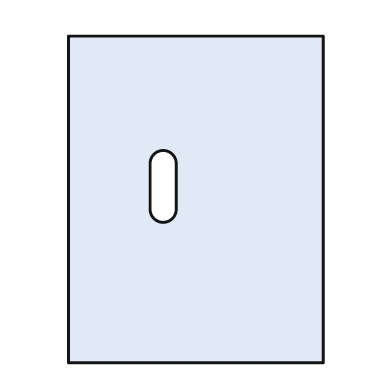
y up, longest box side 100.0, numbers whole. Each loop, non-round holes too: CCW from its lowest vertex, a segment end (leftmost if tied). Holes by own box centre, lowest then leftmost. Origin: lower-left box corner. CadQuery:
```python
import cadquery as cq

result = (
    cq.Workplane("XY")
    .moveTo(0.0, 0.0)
    .lineTo(78.0, 0.0)
    .lineTo(78.0, 100.0)
    .lineTo(0.0, 100.0)
    .close()
    .moveTo(25.0, 47.0)
    .threePointArc((29.0, 43.0), (33.0, 47.0))
    .lineTo(33.0, 61.0)
    .threePointArc((29.0, 65.0), (25.0, 61.0))
    .close()
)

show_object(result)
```